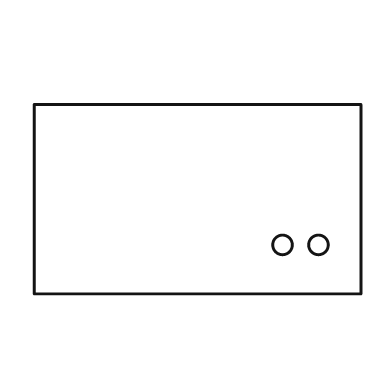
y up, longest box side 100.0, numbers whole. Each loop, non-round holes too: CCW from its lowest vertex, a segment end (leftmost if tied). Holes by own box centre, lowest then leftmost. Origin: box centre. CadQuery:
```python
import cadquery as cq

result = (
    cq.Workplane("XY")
    .moveTo(-50.0, -29.0)
    .lineTo(50.0, -29.0)
    .lineTo(50.0, 29.0)
    .lineTo(-50.0, 29.0)
    .close()
    .moveTo(26.0, -14.0)
    .circle(3.0)
    .moveTo(37.0, -14.0)
    .circle(3.0)
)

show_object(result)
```